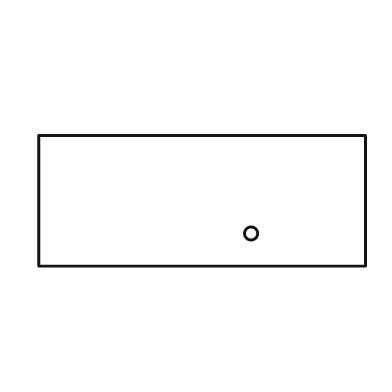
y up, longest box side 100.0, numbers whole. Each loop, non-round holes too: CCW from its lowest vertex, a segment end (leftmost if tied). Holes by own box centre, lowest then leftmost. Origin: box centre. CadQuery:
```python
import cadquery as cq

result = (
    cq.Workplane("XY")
    .moveTo(-50.0, -20.0)
    .lineTo(50.0, -20.0)
    .lineTo(50.0, 20.0)
    .lineTo(-50.0, 20.0)
    .close()
    .moveTo(15.0, -10.0)
    .circle(2.0)
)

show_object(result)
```